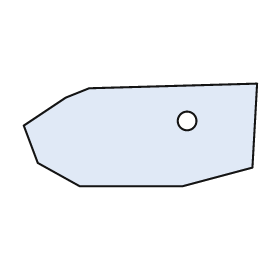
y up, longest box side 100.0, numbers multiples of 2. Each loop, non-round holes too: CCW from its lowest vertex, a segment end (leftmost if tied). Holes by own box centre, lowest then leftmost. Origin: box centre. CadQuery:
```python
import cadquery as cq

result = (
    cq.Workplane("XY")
    .moveTo(-26.0, -22.0)
    .lineTo(18.0, -22.0)
    .lineTo(48.0, -14.0)
    .lineTo(50.0, 22.0)
    .lineTo(-22.0, 20.0)
    .lineTo(-32.0, 16.0)
    .lineTo(-50.0, 4.0)
    .lineTo(-44.0, -12.0)
    .close()
    .moveTo(20.0, 6.0)
    .circle(4.0)
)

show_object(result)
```